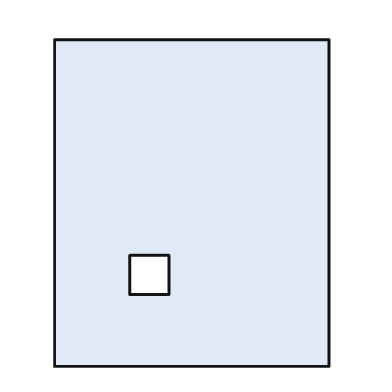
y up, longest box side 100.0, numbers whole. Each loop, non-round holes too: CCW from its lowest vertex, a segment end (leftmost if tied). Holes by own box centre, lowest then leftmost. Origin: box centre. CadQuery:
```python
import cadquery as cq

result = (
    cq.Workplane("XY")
    .moveTo(-42.0, -50.0)
    .lineTo(42.0, -50.0)
    .lineTo(42.0, 50.0)
    .lineTo(-42.0, 50.0)
    .close()
    .moveTo(-19.0, -28.0)
    .lineTo(-7.0, -28.0)
    .lineTo(-7.0, -16.0)
    .lineTo(-19.0, -16.0)
    .close()
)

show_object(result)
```